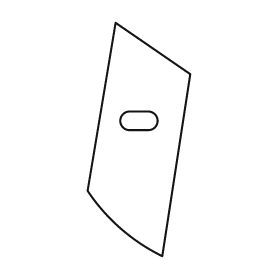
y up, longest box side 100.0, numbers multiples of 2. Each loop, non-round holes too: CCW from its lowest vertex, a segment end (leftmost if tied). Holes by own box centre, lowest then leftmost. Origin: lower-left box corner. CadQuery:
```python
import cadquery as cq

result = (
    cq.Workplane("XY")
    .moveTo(32.0, 0.0)
    .lineTo(44.0, 78.0)
    .lineTo(12.0, 100.0)
    .lineTo(0.0, 28.0)
    .threePointArc((14.0, 12.0), (32.0, 0.0))
    .close()
    .moveTo(18.0, 54.0)
    .lineTo(26.0, 54.0)
    .threePointArc((30.0, 58.0), (26.0, 62.0))
    .lineTo(18.0, 62.0)
    .threePointArc((14.0, 58.0), (18.0, 54.0))
    .close()
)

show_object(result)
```